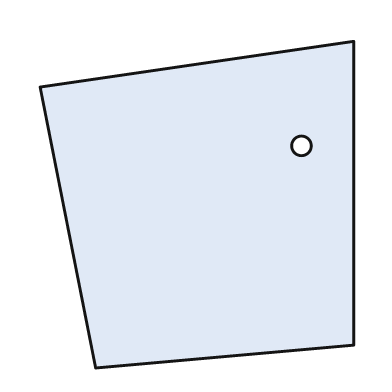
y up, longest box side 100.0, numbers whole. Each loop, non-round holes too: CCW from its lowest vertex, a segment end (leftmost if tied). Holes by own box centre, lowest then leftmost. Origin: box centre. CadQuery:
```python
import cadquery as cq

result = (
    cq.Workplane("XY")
    .moveTo(-31.0, -50.0)
    .lineTo(48.0, -43.0)
    .lineTo(48.0, 50.0)
    .lineTo(-48.0, 36.0)
    .close()
    .moveTo(32.0, 18.0)
    .circle(3.0)
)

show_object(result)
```